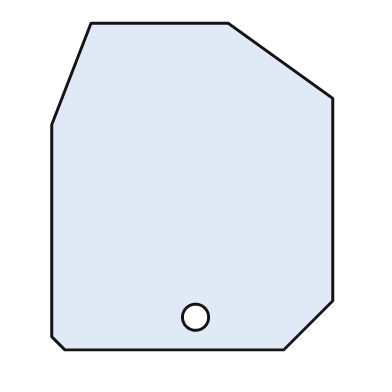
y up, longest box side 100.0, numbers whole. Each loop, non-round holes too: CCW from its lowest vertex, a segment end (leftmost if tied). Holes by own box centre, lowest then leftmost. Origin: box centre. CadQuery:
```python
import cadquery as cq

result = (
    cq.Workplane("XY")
    .moveTo(-39.0, -50.0)
    .lineTo(28.0, -50.0)
    .lineTo(43.0, -35.0)
    .lineTo(43.0, 27.0)
    .lineTo(11.0, 50.0)
    .lineTo(-31.0, 50.0)
    .lineTo(-43.0, 19.0)
    .lineTo(-43.0, -46.0)
    .close()
    .moveTo(1.0, -40.0)
    .circle(4.0)
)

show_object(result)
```